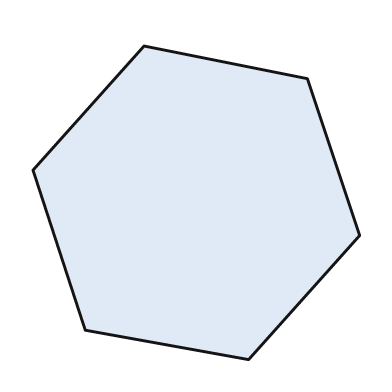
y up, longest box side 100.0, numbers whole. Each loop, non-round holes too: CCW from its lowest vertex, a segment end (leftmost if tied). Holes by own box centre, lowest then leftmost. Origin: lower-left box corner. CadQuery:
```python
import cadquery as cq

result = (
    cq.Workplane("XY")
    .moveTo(66.0, 0.0)
    .lineTo(100.0, 38.0)
    .lineTo(84.0, 86.0)
    .lineTo(34.0, 96.0)
    .lineTo(0.0, 58.0)
    .lineTo(16.0, 9.0)
    .close()
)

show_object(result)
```